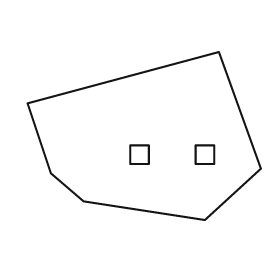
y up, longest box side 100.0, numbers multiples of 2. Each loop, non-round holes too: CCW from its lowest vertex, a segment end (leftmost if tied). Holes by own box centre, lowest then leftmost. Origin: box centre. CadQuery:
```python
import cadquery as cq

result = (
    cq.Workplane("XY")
    .moveTo(26.0, -36.0)
    .lineTo(50.0, -14.0)
    .lineTo(32.0, 36.0)
    .lineTo(-50.0, 14.0)
    .lineTo(-40.0, -16.0)
    .lineTo(-26.0, -28.0)
    .close()
    .moveTo(-6.0, -12.0)
    .lineTo(2.0, -12.0)
    .lineTo(2.0, -4.0)
    .lineTo(-6.0, -4.0)
    .close()
    .moveTo(22.0, -12.0)
    .lineTo(30.0, -12.0)
    .lineTo(30.0, -4.0)
    .lineTo(22.0, -4.0)
    .close()
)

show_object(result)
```